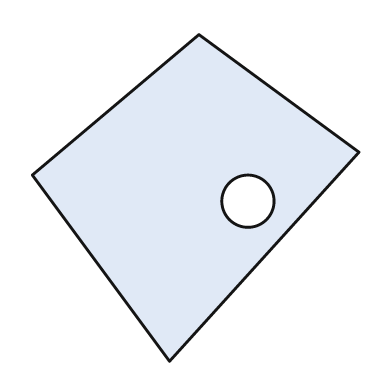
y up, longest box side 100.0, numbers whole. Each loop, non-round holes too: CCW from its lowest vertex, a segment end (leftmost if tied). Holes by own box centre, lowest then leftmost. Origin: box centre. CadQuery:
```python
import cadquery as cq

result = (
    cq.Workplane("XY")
    .moveTo(-8.0, -50.0)
    .lineTo(50.0, 14.0)
    .lineTo(1.0, 50.0)
    .lineTo(-50.0, 7.0)
    .close()
    .moveTo(16.0, -1.0)
    .circle(8.0)
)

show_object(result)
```